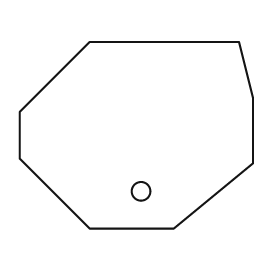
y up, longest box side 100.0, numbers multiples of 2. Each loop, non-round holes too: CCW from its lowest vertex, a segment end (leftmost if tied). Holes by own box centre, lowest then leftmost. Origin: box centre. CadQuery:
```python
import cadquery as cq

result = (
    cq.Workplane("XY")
    .moveTo(-20.0, -40.0)
    .lineTo(16.0, -40.0)
    .lineTo(50.0, -12.0)
    .lineTo(50.0, 16.0)
    .lineTo(44.0, 40.0)
    .lineTo(-20.0, 40.0)
    .lineTo(-50.0, 10.0)
    .lineTo(-50.0, -10.0)
    .close()
    .moveTo(2.0, -24.0)
    .circle(4.0)
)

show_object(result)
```